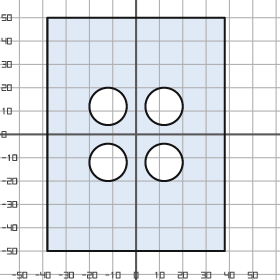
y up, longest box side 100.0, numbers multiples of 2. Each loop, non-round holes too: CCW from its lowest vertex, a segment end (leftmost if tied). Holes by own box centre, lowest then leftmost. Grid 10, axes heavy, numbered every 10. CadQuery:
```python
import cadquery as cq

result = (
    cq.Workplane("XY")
    .moveTo(-38.0, -50.0)
    .lineTo(38.0, -50.0)
    .lineTo(38.0, 50.0)
    .lineTo(-38.0, 50.0)
    .close()
    .moveTo(-12.0, -12.0)
    .circle(8.0)
    .moveTo(12.0, -12.0)
    .circle(8.0)
    .moveTo(-12.0, 12.0)
    .circle(8.0)
    .moveTo(12.0, 12.0)
    .circle(8.0)
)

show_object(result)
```